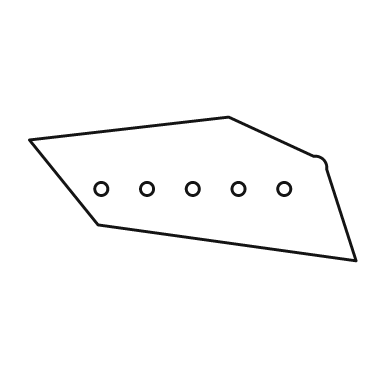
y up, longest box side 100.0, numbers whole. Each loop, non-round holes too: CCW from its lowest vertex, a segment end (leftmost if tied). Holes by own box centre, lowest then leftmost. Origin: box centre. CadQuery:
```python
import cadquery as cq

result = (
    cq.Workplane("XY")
    .moveTo(50.0, -22.0)
    .lineTo(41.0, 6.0)
    .threePointArc((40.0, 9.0), (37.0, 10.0))
    .lineTo(11.0, 22.0)
    .lineTo(-50.0, 15.0)
    .lineTo(-29.0, -11.0)
    .close()
    .moveTo(-28.0, 0.0)
    .circle(2.0)
    .moveTo(-14.0, 0.0)
    .circle(2.0)
    .moveTo(0.0, 0.0)
    .circle(2.0)
    .moveTo(14.0, 0.0)
    .circle(2.0)
    .moveTo(28.0, 0.0)
    .circle(2.0)
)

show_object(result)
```